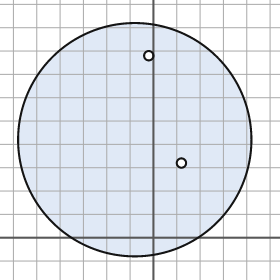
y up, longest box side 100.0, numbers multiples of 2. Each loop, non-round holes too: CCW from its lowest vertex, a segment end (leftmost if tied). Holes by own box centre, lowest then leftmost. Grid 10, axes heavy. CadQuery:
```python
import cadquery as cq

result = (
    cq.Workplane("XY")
    .moveTo(-8.0, 42.0)
    .circle(50.0)
    .moveTo(12.0, 32.0)
    .circle(2.0)
    .moveTo(-2.0, 78.0)
    .circle(2.0)
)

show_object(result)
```